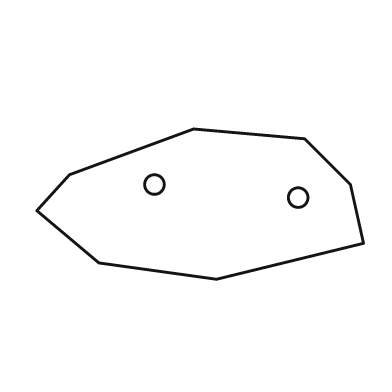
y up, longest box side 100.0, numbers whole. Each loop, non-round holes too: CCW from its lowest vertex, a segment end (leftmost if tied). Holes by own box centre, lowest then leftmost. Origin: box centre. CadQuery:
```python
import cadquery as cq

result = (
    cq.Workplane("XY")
    .moveTo(5.0, -23.0)
    .lineTo(50.0, -12.0)
    .lineTo(46.0, 6.0)
    .lineTo(32.0, 20.0)
    .lineTo(-2.0, 23.0)
    .lineTo(-40.0, 9.0)
    .lineTo(-50.0, -2.0)
    .lineTo(-31.0, -18.0)
    .close()
    .moveTo(30.0, 2.0)
    .circle(3.0)
    .moveTo(-14.0, 6.0)
    .circle(3.0)
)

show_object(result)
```